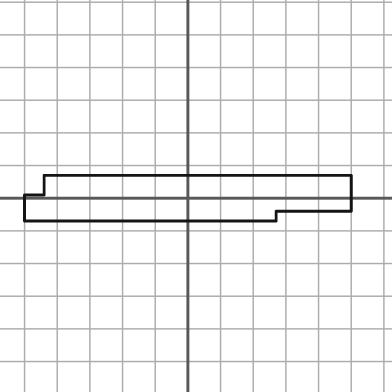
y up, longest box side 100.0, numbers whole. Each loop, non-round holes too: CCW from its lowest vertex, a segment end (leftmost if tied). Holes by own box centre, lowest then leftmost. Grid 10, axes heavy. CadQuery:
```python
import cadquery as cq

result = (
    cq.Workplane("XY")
    .moveTo(-50.0, -7.0)
    .lineTo(27.0, -7.0)
    .lineTo(27.0, -4.0)
    .lineTo(50.0, -4.0)
    .lineTo(50.0, 7.0)
    .lineTo(-44.0, 7.0)
    .lineTo(-44.0, 1.0)
    .lineTo(-50.0, 1.0)
    .close()
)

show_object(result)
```